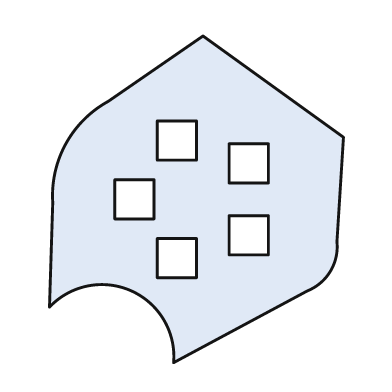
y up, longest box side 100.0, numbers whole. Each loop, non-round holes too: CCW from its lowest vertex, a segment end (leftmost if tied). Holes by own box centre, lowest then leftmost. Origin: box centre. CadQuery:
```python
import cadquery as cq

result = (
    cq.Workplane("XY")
    .moveTo(-7.0, -50.0)
    .lineTo(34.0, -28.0)
    .threePointArc((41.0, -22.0), (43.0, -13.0))
    .lineTo(45.0, 19.0)
    .lineTo(2.0, 50.0)
    .lineTo(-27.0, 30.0)
    .threePointArc((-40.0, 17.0), (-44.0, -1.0))
    .lineTo(-45.0, -33.0)
    .threePointArc((-20.0, -28.0), (-7.0, -50.0))
    .close()
    .moveTo(-12.0, -24.0)
    .lineTo(0.0, -24.0)
    .lineTo(0.0, -12.0)
    .lineTo(-12.0, -12.0)
    .close()
    .moveTo(10.0, -17.0)
    .lineTo(22.0, -17.0)
    .lineTo(22.0, -5.0)
    .lineTo(10.0, -5.0)
    .close()
    .moveTo(-25.0, -6.0)
    .lineTo(-13.0, -6.0)
    .lineTo(-13.0, 6.0)
    .lineTo(-25.0, 6.0)
    .close()
    .moveTo(10.0, 5.0)
    .lineTo(22.0, 5.0)
    .lineTo(22.0, 17.0)
    .lineTo(10.0, 17.0)
    .close()
    .moveTo(-12.0, 12.0)
    .lineTo(0.0, 12.0)
    .lineTo(0.0, 24.0)
    .lineTo(-12.0, 24.0)
    .close()
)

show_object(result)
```